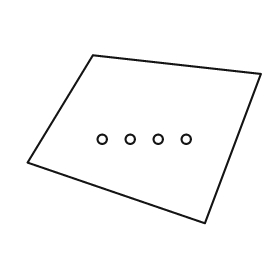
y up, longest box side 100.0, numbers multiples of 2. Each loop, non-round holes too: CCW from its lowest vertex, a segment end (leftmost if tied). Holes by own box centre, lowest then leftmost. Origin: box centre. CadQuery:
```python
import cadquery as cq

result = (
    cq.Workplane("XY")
    .moveTo(26.0, -36.0)
    .lineTo(50.0, 28.0)
    .lineTo(-22.0, 36.0)
    .lineTo(-50.0, -10.0)
    .close()
    .moveTo(-18.0, 0.0)
    .circle(2.0)
    .moveTo(-6.0, 0.0)
    .circle(2.0)
    .moveTo(6.0, 0.0)
    .circle(2.0)
    .moveTo(18.0, 0.0)
    .circle(2.0)
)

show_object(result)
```